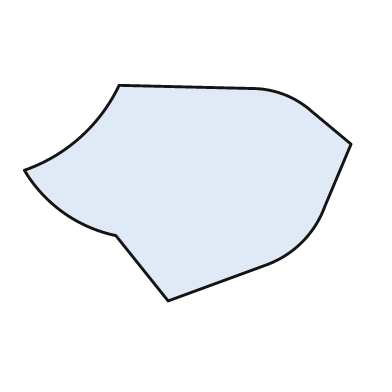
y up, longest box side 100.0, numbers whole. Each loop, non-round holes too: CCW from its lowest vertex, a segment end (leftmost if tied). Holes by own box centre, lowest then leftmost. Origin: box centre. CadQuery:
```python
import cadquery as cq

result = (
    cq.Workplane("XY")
    .moveTo(-6.0, -33.0)
    .lineTo(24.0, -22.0)
    .threePointArc((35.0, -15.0), (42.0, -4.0))
    .lineTo(50.0, 15.0)
    .lineTo(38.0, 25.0)
    .threePointArc((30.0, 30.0), (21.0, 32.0))
    .lineTo(-21.0, 33.0)
    .threePointArc((-33.0, 17.0), (-50.0, 7.0))
    .threePointArc((-38.0, -6.0), (-22.0, -13.0))
    .close()
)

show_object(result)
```